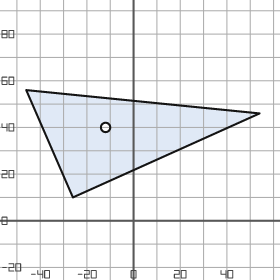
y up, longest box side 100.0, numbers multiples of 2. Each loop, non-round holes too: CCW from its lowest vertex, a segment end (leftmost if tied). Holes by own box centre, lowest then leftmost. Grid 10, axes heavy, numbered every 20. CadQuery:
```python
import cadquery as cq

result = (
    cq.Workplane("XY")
    .moveTo(-26.0, 10.0)
    .lineTo(54.0, 46.0)
    .lineTo(-46.0, 56.0)
    .close()
    .moveTo(-12.0, 40.0)
    .circle(2.0)
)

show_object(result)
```